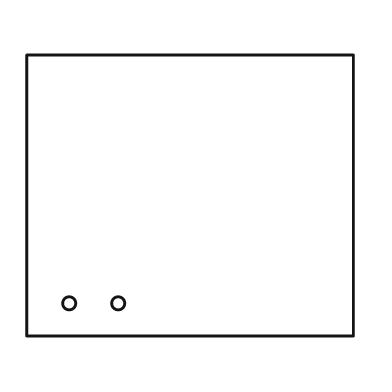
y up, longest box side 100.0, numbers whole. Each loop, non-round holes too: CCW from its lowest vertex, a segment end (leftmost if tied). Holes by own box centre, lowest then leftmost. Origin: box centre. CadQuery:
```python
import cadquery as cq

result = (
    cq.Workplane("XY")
    .moveTo(-50.0, -43.0)
    .lineTo(50.0, -43.0)
    .lineTo(50.0, 43.0)
    .lineTo(-50.0, 43.0)
    .close()
    .moveTo(-37.0, -33.0)
    .circle(2.0)
    .moveTo(-22.0, -33.0)
    .circle(2.0)
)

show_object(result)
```